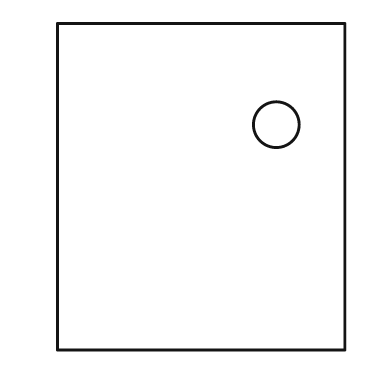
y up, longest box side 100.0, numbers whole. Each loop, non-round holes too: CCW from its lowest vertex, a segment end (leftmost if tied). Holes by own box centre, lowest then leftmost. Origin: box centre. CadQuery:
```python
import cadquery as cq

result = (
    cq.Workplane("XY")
    .moveTo(-44.0, -50.0)
    .lineTo(44.0, -50.0)
    .lineTo(44.0, 50.0)
    .lineTo(-44.0, 50.0)
    .close()
    .moveTo(23.0, 19.0)
    .circle(7.0)
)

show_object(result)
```